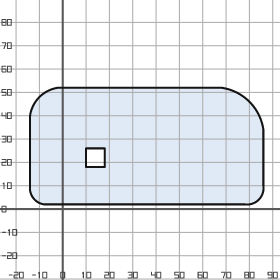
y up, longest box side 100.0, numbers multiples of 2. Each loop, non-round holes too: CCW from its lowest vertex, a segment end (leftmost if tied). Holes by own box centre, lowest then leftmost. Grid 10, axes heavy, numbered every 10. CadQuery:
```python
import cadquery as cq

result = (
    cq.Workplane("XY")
    .moveTo(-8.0, 2.0)
    .lineTo(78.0, 2.0)
    .threePointArc((84.0, 4.0), (86.0, 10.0))
    .lineTo(86.0, 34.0)
    .threePointArc((80.0, 46.0), (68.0, 52.0))
    .lineTo(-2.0, 52.0)
    .threePointArc((-10.0, 48.0), (-14.0, 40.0))
    .lineTo(-14.0, 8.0)
    .threePointArc((-12.0, 4.0), (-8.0, 2.0))
    .close()
    .moveTo(10.0, 18.0)
    .lineTo(18.0, 18.0)
    .lineTo(18.0, 26.0)
    .lineTo(10.0, 26.0)
    .close()
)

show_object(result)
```